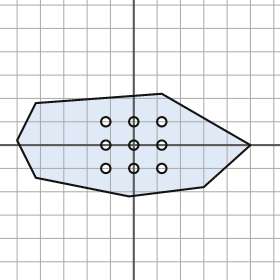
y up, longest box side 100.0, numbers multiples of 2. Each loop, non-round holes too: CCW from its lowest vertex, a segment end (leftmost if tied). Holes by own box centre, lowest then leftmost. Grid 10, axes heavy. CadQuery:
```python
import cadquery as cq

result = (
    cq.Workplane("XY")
    .moveTo(-2.0, -22.0)
    .lineTo(30.0, -18.0)
    .lineTo(50.0, 0.0)
    .lineTo(12.0, 22.0)
    .lineTo(-42.0, 18.0)
    .lineTo(-50.0, 2.0)
    .lineTo(-42.0, -14.0)
    .close()
    .moveTo(-12.0, -10.0)
    .circle(2.0)
    .moveTo(0.0, -10.0)
    .circle(2.0)
    .moveTo(12.0, -10.0)
    .circle(2.0)
    .moveTo(-12.0, 0.0)
    .circle(2.0)
    .moveTo(0.0, 0.0)
    .circle(2.0)
    .moveTo(12.0, 0.0)
    .circle(2.0)
    .moveTo(-12.0, 10.0)
    .circle(2.0)
    .moveTo(0.0, 10.0)
    .circle(2.0)
    .moveTo(12.0, 10.0)
    .circle(2.0)
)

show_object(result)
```